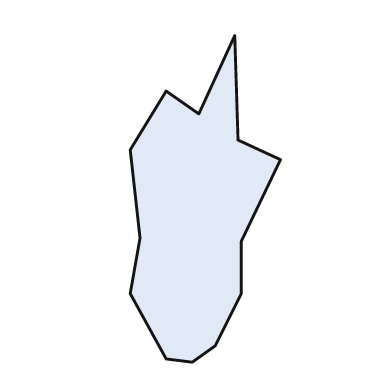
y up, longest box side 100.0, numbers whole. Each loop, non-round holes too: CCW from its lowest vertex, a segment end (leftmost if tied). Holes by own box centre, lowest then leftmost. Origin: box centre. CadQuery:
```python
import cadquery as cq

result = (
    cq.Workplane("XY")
    .moveTo(-4.0, -50.0)
    .lineTo(3.0, -45.0)
    .lineTo(11.0, -29.0)
    .lineTo(11.0, -13.0)
    .lineTo(23.0, 12.0)
    .lineTo(10.0, 18.0)
    .lineTo(9.0, 50.0)
    .lineTo(-2.0, 26.0)
    .lineTo(-12.0, 33.0)
    .lineTo(-23.0, 15.0)
    .lineTo(-20.0, -12.0)
    .lineTo(-23.0, -29.0)
    .lineTo(-12.0, -49.0)
    .close()
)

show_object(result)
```